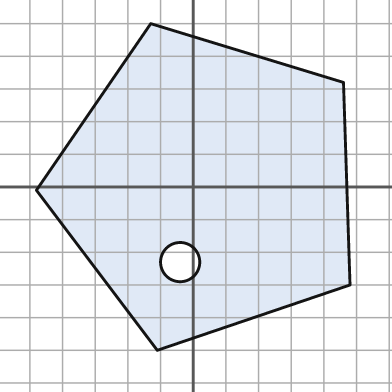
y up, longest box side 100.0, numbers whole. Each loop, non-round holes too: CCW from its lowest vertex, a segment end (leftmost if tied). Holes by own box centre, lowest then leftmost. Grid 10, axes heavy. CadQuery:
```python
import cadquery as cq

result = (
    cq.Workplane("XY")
    .moveTo(-11.0, -50.0)
    .lineTo(48.0, -30.0)
    .lineTo(46.0, 32.0)
    .lineTo(-13.0, 50.0)
    .lineTo(-48.0, -1.0)
    .close()
    .moveTo(-4.0, -23.0)
    .circle(6.0)
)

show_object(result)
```